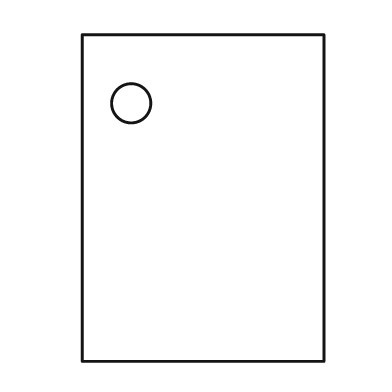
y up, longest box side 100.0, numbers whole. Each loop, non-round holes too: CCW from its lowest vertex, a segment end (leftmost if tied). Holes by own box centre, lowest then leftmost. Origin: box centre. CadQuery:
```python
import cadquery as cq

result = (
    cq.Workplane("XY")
    .moveTo(-37.0, -50.0)
    .lineTo(37.0, -50.0)
    .lineTo(37.0, 50.0)
    .lineTo(-37.0, 50.0)
    .close()
    .moveTo(-22.0, 29.0)
    .circle(6.0)
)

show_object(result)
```